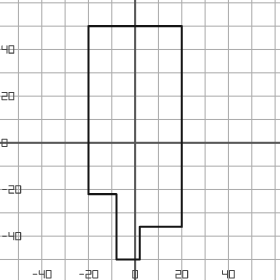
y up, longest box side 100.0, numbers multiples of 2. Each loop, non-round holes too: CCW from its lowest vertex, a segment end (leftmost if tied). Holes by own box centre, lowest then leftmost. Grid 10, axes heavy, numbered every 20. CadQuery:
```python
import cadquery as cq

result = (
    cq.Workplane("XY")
    .moveTo(-8.0, -50.0)
    .lineTo(2.0, -50.0)
    .lineTo(2.0, -36.0)
    .lineTo(20.0, -36.0)
    .lineTo(20.0, 50.0)
    .lineTo(-20.0, 50.0)
    .lineTo(-20.0, -22.0)
    .lineTo(-8.0, -22.0)
    .close()
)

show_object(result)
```